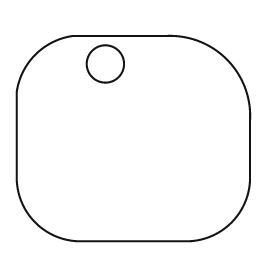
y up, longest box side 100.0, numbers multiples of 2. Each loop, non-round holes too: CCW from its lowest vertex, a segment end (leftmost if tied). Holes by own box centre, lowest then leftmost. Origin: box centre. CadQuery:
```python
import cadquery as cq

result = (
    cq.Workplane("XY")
    .moveTo(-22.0, -44.0)
    .lineTo(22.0, -44.0)
    .threePointArc((42.0, -36.0), (50.0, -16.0))
    .lineTo(50.0, 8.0)
    .threePointArc((40.0, 34.0), (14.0, 44.0))
    .lineTo(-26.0, 44.0)
    .threePointArc((-42.0, 36.0), (-50.0, 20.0))
    .lineTo(-50.0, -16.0)
    .threePointArc((-42.0, -36.0), (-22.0, -44.0))
    .close()
    .moveTo(-12.0, 32.0)
    .circle(8.0)
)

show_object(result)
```